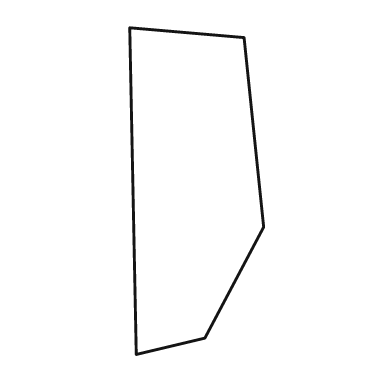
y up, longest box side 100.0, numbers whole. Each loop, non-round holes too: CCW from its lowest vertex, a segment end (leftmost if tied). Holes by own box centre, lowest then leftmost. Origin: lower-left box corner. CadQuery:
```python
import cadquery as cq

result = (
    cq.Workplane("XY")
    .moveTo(2.0, 0.0)
    .lineTo(23.0, 5.0)
    .lineTo(41.0, 39.0)
    .lineTo(35.0, 97.0)
    .lineTo(0.0, 100.0)
    .close()
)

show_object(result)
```